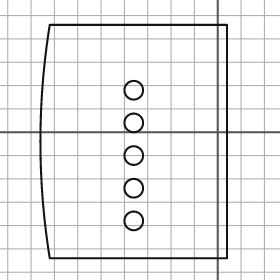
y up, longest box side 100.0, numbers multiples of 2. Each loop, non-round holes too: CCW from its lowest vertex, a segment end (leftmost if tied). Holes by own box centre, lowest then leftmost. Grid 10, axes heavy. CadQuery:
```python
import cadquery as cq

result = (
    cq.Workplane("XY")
    .moveTo(-72.0, -54.0)
    .lineTo(4.0, -54.0)
    .lineTo(4.0, 46.0)
    .lineTo(-72.0, 46.0)
    .threePointArc((-76.0, -4.0), (-72.0, -54.0))
    .close()
    .moveTo(-36.0, -38.0)
    .circle(4.0)
    .moveTo(-36.0, -24.0)
    .circle(4.0)
    .moveTo(-36.0, -10.0)
    .circle(4.0)
    .moveTo(-36.0, 4.0)
    .circle(4.0)
    .moveTo(-36.0, 18.0)
    .circle(4.0)
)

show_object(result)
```